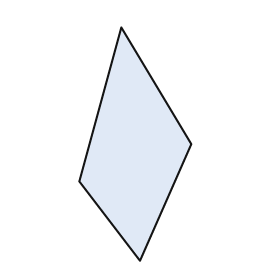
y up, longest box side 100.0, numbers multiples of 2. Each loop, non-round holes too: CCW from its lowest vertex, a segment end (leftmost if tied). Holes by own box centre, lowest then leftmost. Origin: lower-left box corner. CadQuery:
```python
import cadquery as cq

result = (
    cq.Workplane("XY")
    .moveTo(26.0, 0.0)
    .lineTo(48.0, 50.0)
    .lineTo(18.0, 100.0)
    .lineTo(0.0, 34.0)
    .close()
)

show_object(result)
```